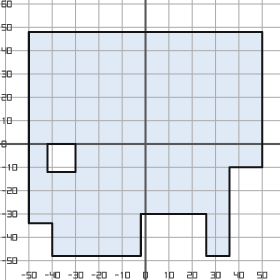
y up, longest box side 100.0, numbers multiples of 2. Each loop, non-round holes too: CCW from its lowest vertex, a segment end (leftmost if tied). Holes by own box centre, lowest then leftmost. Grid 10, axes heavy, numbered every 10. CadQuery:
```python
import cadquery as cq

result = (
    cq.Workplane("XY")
    .moveTo(-40.0, -48.0)
    .lineTo(-2.0, -48.0)
    .lineTo(-2.0, -30.0)
    .lineTo(26.0, -30.0)
    .lineTo(26.0, -48.0)
    .lineTo(36.0, -48.0)
    .lineTo(36.0, -10.0)
    .lineTo(50.0, -10.0)
    .lineTo(50.0, 48.0)
    .lineTo(-50.0, 48.0)
    .lineTo(-50.0, -34.0)
    .lineTo(-40.0, -34.0)
    .close()
    .moveTo(-42.0, -12.0)
    .lineTo(-30.0, -12.0)
    .lineTo(-30.0, 0.0)
    .lineTo(-42.0, 0.0)
    .close()
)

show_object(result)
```